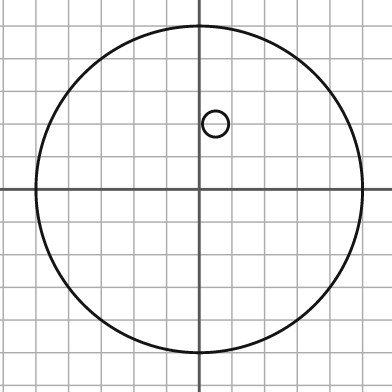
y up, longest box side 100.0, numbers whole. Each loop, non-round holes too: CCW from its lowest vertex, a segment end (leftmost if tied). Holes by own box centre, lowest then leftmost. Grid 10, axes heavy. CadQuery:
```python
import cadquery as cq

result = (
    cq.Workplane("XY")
    .moveTo(0.0, 0.0)
    .circle(50.0)
    .moveTo(5.0, 20.0)
    .circle(4.0)
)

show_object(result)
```